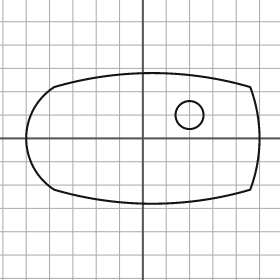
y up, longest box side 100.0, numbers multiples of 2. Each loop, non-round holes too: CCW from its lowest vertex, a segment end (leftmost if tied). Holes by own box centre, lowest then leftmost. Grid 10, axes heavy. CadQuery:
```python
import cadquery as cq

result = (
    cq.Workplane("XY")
    .moveTo(-38.0, -22.0)
    .threePointArc((4.0, -28.0), (46.0, -22.0))
    .threePointArc((50.0, 0.0), (46.0, 22.0))
    .threePointArc((4.0, 28.0), (-38.0, 22.0))
    .threePointArc((-50.0, 0.0), (-38.0, -22.0))
    .close()
    .moveTo(20.0, 10.0)
    .circle(6.0)
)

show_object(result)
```